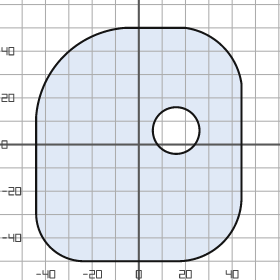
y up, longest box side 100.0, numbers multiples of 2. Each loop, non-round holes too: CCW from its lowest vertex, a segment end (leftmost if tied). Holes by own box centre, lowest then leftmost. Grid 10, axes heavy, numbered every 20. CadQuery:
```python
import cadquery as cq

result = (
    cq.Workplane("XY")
    .moveTo(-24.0, -50.0)
    .lineTo(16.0, -50.0)
    .threePointArc((36.0, -42.0), (44.0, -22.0))
    .lineTo(44.0, 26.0)
    .threePointArc((36.0, 42.0), (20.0, 50.0))
    .lineTo(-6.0, 50.0)
    .threePointArc((-32.0, 38.0), (-44.0, 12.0))
    .lineTo(-44.0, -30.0)
    .threePointArc((-38.0, -44.0), (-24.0, -50.0))
    .close()
    .moveTo(16.0, 6.0)
    .circle(10.0)
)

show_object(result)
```